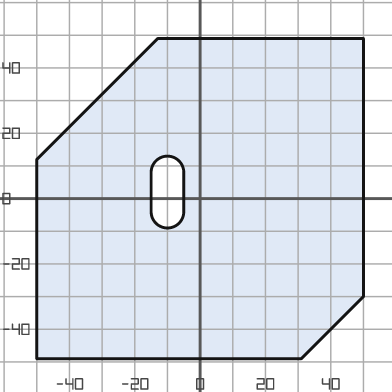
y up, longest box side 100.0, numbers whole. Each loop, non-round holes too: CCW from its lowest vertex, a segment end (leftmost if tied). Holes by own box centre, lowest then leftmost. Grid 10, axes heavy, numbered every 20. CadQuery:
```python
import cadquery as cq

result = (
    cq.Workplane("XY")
    .moveTo(-50.0, -49.0)
    .lineTo(31.0, -49.0)
    .lineTo(50.0, -30.0)
    .lineTo(50.0, 49.0)
    .lineTo(-13.0, 49.0)
    .lineTo(-50.0, 12.0)
    .close()
    .moveTo(-15.0, -4.0)
    .threePointArc((-10.0, -9.0), (-5.0, -4.0))
    .lineTo(-5.0, 8.0)
    .threePointArc((-10.0, 13.0), (-15.0, 8.0))
    .close()
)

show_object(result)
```